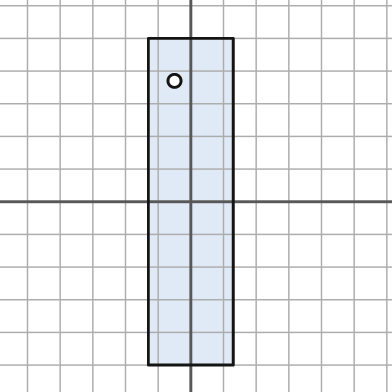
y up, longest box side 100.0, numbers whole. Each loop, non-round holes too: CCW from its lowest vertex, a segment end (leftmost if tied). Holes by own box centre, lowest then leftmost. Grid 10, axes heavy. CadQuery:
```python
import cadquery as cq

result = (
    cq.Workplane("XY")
    .moveTo(-13.0, -50.0)
    .lineTo(13.0, -50.0)
    .lineTo(13.0, 50.0)
    .lineTo(-13.0, 50.0)
    .close()
    .moveTo(-5.0, 37.0)
    .circle(2.0)
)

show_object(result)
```